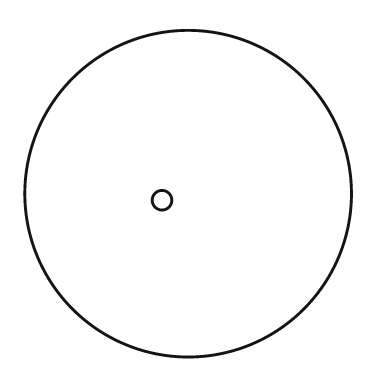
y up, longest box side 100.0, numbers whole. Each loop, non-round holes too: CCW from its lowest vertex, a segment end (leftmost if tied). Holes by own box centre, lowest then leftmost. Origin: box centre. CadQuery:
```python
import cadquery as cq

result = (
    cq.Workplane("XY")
    .moveTo(0.0, 0.0)
    .circle(50.0)
    .moveTo(-8.0, -2.0)
    .circle(3.0)
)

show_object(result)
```